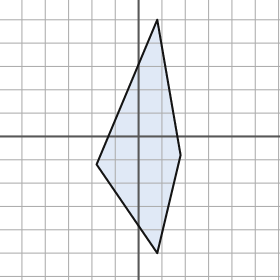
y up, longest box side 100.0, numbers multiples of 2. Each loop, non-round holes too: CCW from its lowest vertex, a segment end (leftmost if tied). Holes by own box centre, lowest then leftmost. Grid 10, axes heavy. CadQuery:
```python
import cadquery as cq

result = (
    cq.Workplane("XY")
    .moveTo(8.0, -50.0)
    .lineTo(18.0, -8.0)
    .lineTo(8.0, 50.0)
    .lineTo(-18.0, -12.0)
    .close()
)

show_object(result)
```